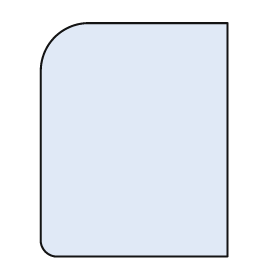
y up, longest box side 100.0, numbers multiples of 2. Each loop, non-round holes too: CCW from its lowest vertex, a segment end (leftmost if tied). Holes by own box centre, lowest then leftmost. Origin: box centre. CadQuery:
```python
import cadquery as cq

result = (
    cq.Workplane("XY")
    .moveTo(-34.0, -50.0)
    .lineTo(40.0, -50.0)
    .lineTo(40.0, 50.0)
    .lineTo(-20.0, 50.0)
    .threePointArc((-34.0, 44.0), (-40.0, 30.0))
    .lineTo(-40.0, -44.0)
    .threePointArc((-38.0, -48.0), (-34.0, -50.0))
    .close()
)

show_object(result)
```